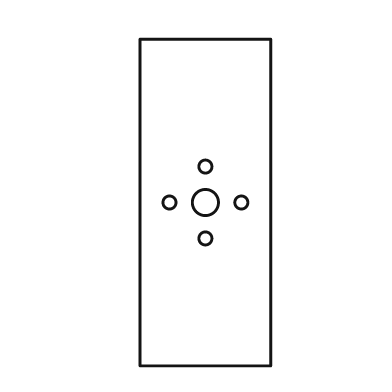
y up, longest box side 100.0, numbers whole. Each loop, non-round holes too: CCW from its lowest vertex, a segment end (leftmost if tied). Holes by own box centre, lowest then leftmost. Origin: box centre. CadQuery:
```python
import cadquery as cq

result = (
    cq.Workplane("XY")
    .moveTo(-20.0, -50.0)
    .lineTo(20.0, -50.0)
    .lineTo(20.0, 50.0)
    .lineTo(-20.0, 50.0)
    .close()
    .moveTo(0.0, -11.0)
    .circle(2.0)
    .moveTo(-11.0, 0.0)
    .circle(2.0)
    .moveTo(0.0, 0.0)
    .circle(4.0)
    .moveTo(11.0, 0.0)
    .circle(2.0)
    .moveTo(0.0, 11.0)
    .circle(2.0)
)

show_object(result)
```